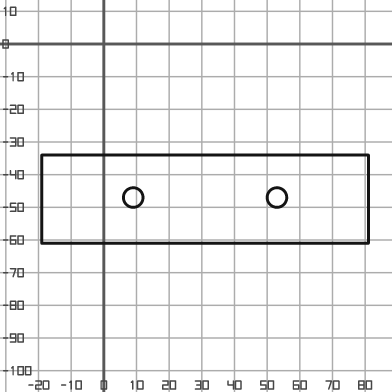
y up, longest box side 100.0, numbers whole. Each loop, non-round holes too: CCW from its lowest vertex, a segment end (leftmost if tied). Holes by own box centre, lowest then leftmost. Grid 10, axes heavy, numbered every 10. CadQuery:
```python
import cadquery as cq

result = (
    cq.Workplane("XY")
    .moveTo(-19.0, -61.0)
    .lineTo(81.0, -61.0)
    .lineTo(81.0, -34.0)
    .lineTo(-19.0, -34.0)
    .close()
    .moveTo(9.0, -47.0)
    .circle(3.0)
    .moveTo(53.0, -47.0)
    .circle(3.0)
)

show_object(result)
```